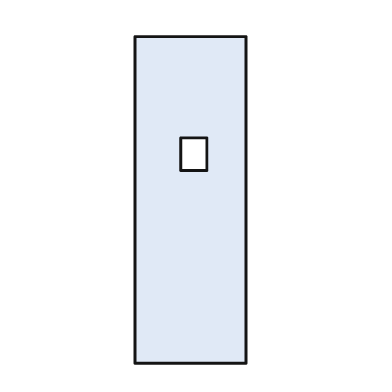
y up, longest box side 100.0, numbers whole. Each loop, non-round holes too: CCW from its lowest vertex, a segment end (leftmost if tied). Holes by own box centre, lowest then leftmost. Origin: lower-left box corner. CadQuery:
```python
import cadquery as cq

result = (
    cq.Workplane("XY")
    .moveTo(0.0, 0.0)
    .lineTo(34.0, 0.0)
    .lineTo(34.0, 100.0)
    .lineTo(0.0, 100.0)
    .close()
    .moveTo(14.0, 59.0)
    .lineTo(22.0, 59.0)
    .lineTo(22.0, 69.0)
    .lineTo(14.0, 69.0)
    .close()
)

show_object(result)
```